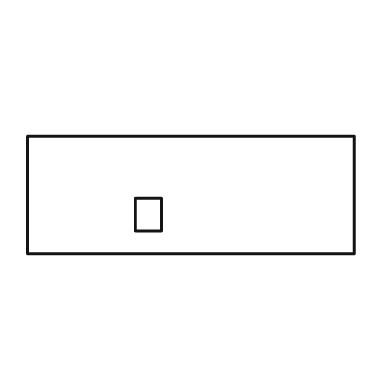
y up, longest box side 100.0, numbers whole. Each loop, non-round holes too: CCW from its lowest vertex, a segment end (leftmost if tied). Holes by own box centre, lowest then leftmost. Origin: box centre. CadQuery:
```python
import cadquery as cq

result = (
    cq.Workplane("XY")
    .moveTo(-50.0, -18.0)
    .lineTo(50.0, -18.0)
    .lineTo(50.0, 18.0)
    .lineTo(-50.0, 18.0)
    .close()
    .moveTo(-17.0, -11.0)
    .lineTo(-9.0, -11.0)
    .lineTo(-9.0, -1.0)
    .lineTo(-17.0, -1.0)
    .close()
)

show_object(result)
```